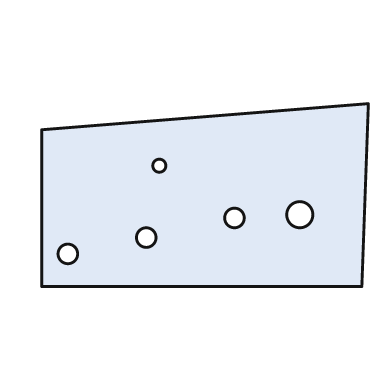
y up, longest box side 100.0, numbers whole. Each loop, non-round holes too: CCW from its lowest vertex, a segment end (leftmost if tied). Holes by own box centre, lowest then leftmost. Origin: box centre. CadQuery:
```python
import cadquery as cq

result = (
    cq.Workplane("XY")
    .moveTo(-50.0, -28.0)
    .lineTo(48.0, -28.0)
    .lineTo(50.0, 28.0)
    .lineTo(-50.0, 20.0)
    .close()
    .moveTo(-42.0, -18.0)
    .circle(3.0)
    .moveTo(-18.0, -13.0)
    .circle(3.0)
    .moveTo(9.0, -7.0)
    .circle(3.0)
    .moveTo(29.0, -6.0)
    .circle(4.0)
    .moveTo(-14.0, 9.0)
    .circle(2.0)
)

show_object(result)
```